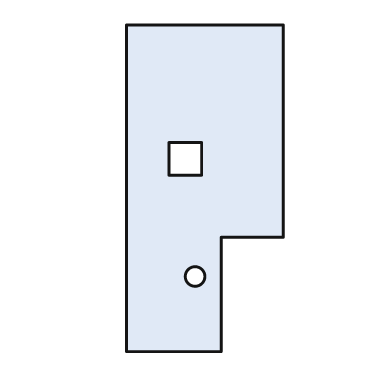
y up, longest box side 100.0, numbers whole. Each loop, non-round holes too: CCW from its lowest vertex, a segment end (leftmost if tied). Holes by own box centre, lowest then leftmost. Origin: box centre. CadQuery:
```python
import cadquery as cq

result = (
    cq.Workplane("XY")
    .moveTo(-24.0, -50.0)
    .lineTo(5.0, -50.0)
    .lineTo(5.0, -15.0)
    .lineTo(24.0, -15.0)
    .lineTo(24.0, 50.0)
    .lineTo(-24.0, 50.0)
    .close()
    .moveTo(-3.0, -27.0)
    .circle(3.0)
    .moveTo(-11.0, 4.0)
    .lineTo(-1.0, 4.0)
    .lineTo(-1.0, 14.0)
    .lineTo(-11.0, 14.0)
    .close()
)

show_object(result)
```